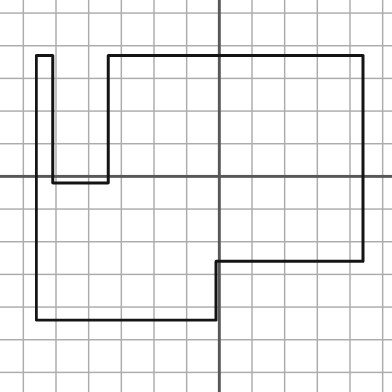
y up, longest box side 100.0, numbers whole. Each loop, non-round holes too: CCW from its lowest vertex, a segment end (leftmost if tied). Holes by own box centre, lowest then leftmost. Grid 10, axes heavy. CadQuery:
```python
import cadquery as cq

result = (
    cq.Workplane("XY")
    .moveTo(-56.0, -44.0)
    .lineTo(-1.0, -44.0)
    .lineTo(-1.0, -26.0)
    .lineTo(44.0, -26.0)
    .lineTo(44.0, 37.0)
    .lineTo(-34.0, 37.0)
    .lineTo(-34.0, -2.0)
    .lineTo(-51.0, -2.0)
    .lineTo(-51.0, 37.0)
    .lineTo(-56.0, 37.0)
    .close()
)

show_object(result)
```